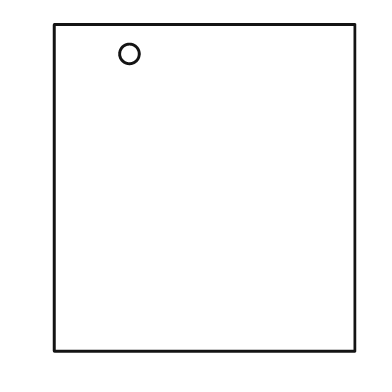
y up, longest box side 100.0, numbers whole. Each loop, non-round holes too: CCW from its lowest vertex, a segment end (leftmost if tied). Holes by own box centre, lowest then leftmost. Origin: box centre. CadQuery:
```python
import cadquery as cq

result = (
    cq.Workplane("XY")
    .moveTo(-46.0, -50.0)
    .lineTo(46.0, -50.0)
    .lineTo(46.0, 50.0)
    .lineTo(-46.0, 50.0)
    .close()
    .moveTo(-23.0, 41.0)
    .circle(3.0)
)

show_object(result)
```